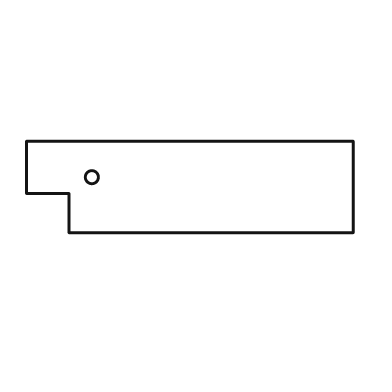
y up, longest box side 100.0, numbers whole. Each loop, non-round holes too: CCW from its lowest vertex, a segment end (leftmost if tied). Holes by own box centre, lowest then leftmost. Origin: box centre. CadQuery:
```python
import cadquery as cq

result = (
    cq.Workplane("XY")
    .moveTo(-37.0, -14.0)
    .lineTo(50.0, -14.0)
    .lineTo(50.0, 14.0)
    .lineTo(-50.0, 14.0)
    .lineTo(-50.0, -2.0)
    .lineTo(-37.0, -2.0)
    .close()
    .moveTo(-30.0, 3.0)
    .circle(2.0)
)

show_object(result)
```